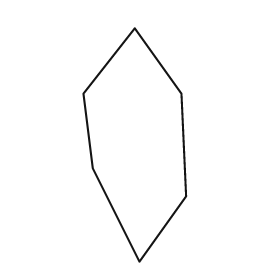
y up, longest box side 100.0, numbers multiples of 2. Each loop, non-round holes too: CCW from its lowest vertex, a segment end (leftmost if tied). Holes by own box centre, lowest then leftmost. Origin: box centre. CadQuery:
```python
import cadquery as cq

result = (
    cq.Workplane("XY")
    .moveTo(2.0, -50.0)
    .lineTo(22.0, -22.0)
    .lineTo(20.0, 22.0)
    .lineTo(0.0, 50.0)
    .lineTo(-22.0, 22.0)
    .lineTo(-18.0, -10.0)
    .close()
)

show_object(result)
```